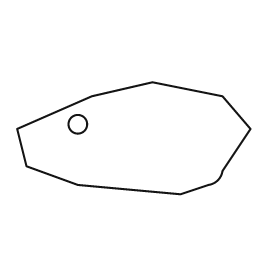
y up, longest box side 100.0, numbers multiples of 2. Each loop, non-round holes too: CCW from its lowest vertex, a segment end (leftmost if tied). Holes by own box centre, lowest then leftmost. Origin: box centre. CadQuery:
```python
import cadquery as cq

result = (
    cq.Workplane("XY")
    .moveTo(20.0, -24.0)
    .lineTo(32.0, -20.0)
    .threePointArc((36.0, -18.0), (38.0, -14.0))
    .lineTo(50.0, 4.0)
    .lineTo(38.0, 18.0)
    .lineTo(8.0, 24.0)
    .lineTo(-18.0, 18.0)
    .lineTo(-50.0, 4.0)
    .lineTo(-46.0, -12.0)
    .lineTo(-24.0, -20.0)
    .close()
    .moveTo(-24.0, 6.0)
    .circle(4.0)
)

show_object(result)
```